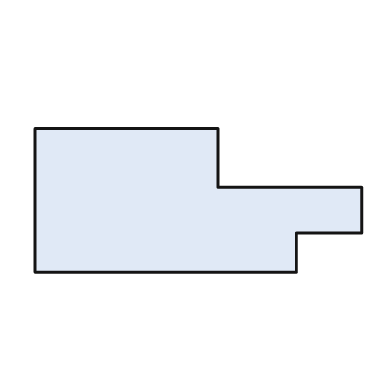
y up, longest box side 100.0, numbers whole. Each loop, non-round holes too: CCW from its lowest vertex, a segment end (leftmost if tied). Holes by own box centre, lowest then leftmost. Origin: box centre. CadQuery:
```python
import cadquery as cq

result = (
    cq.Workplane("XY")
    .moveTo(-50.0, -22.0)
    .lineTo(30.0, -22.0)
    .lineTo(30.0, -10.0)
    .lineTo(50.0, -10.0)
    .lineTo(50.0, 4.0)
    .lineTo(6.0, 4.0)
    .lineTo(6.0, 22.0)
    .lineTo(-50.0, 22.0)
    .close()
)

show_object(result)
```